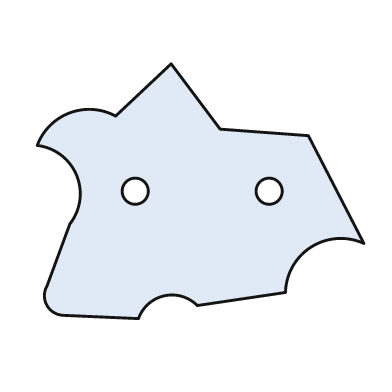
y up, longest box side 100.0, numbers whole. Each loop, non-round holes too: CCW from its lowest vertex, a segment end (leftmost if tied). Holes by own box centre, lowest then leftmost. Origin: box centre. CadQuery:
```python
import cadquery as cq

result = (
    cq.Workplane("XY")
    .moveTo(-19.0, -39.0)
    .threePointArc((-11.0, -32.0), (-1.0, -35.0))
    .lineTo(26.0, -31.0)
    .threePointArc((34.0, -17.0), (50.0, -16.0))
    .lineTo(33.0, 17.0)
    .lineTo(6.0, 19.0)
    .lineTo(-9.0, 39.0)
    .lineTo(-26.0, 23.0)
    .threePointArc((-40.0, 24.0), (-50.0, 14.0))
    .threePointArc((-38.0, 5.0), (-40.0, -10.0))
    .lineTo(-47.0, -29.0)
    .threePointArc((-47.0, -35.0), (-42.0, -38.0))
    .close()
    .moveTo(-20.0, 0.0)
    .circle(4.0)
    .moveTo(21.0, 0.0)
    .circle(4.0)
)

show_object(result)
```